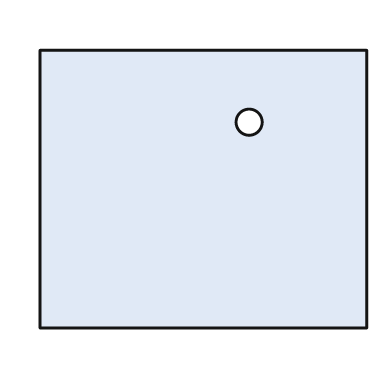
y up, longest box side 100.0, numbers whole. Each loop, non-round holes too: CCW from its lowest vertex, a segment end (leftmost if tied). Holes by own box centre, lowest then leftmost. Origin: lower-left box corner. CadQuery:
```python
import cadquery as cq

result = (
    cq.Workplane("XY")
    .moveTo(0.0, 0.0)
    .lineTo(100.0, 0.0)
    .lineTo(100.0, 85.0)
    .lineTo(0.0, 85.0)
    .close()
    .moveTo(64.0, 63.0)
    .circle(4.0)
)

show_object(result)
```